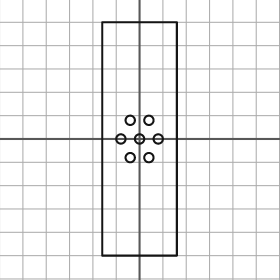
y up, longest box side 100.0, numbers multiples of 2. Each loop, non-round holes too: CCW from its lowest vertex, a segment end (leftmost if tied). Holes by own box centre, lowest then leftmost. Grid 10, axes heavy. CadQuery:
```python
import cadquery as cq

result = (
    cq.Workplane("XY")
    .moveTo(-16.0, -50.0)
    .lineTo(16.0, -50.0)
    .lineTo(16.0, 50.0)
    .lineTo(-16.0, 50.0)
    .close()
    .moveTo(-4.0, -8.0)
    .circle(2.0)
    .moveTo(4.0, -8.0)
    .circle(2.0)
    .moveTo(-8.0, 0.0)
    .circle(2.0)
    .moveTo(0.0, 0.0)
    .circle(2.0)
    .moveTo(8.0, 0.0)
    .circle(2.0)
    .moveTo(-4.0, 8.0)
    .circle(2.0)
    .moveTo(4.0, 8.0)
    .circle(2.0)
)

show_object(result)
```